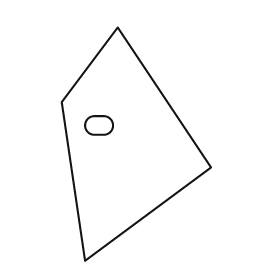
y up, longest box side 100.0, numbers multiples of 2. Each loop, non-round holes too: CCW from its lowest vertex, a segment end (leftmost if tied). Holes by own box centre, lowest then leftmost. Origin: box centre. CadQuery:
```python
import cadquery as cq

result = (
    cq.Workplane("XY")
    .moveTo(-22.0, -50.0)
    .lineTo(32.0, -10.0)
    .lineTo(-8.0, 50.0)
    .lineTo(-32.0, 18.0)
    .close()
    .moveTo(-18.0, 4.0)
    .lineTo(-14.0, 4.0)
    .threePointArc((-10.0, 8.0), (-14.0, 12.0))
    .lineTo(-18.0, 12.0)
    .threePointArc((-22.0, 8.0), (-18.0, 4.0))
    .close()
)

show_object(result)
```